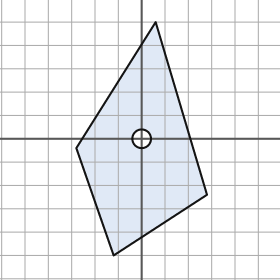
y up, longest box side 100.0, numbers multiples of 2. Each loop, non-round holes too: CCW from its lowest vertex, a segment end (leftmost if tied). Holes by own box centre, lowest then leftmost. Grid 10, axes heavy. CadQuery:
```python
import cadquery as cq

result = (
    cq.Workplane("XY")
    .moveTo(-12.0, -50.0)
    .lineTo(28.0, -24.0)
    .lineTo(6.0, 50.0)
    .lineTo(-28.0, -4.0)
    .close()
    .moveTo(0.0, 0.0)
    .circle(4.0)
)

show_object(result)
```